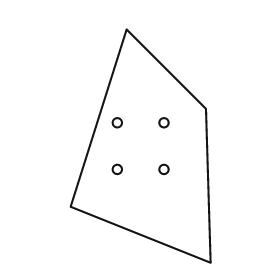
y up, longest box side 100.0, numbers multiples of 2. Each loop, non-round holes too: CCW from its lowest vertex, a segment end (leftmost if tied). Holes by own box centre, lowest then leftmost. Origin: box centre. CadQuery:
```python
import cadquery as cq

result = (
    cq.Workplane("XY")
    .moveTo(30.0, -50.0)
    .lineTo(28.0, 16.0)
    .lineTo(-6.0, 50.0)
    .lineTo(-30.0, -26.0)
    .close()
    .moveTo(-10.0, -10.0)
    .circle(2.0)
    .moveTo(10.0, -10.0)
    .circle(2.0)
    .moveTo(-10.0, 10.0)
    .circle(2.0)
    .moveTo(10.0, 10.0)
    .circle(2.0)
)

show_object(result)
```